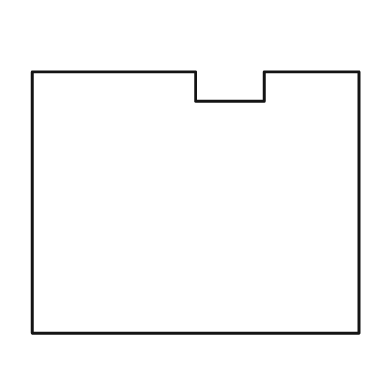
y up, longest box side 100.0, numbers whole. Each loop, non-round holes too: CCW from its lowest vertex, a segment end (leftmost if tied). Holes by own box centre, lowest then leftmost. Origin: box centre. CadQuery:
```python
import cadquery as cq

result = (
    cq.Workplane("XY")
    .moveTo(-50.0, -40.0)
    .lineTo(50.0, -40.0)
    .lineTo(50.0, 40.0)
    .lineTo(21.0, 40.0)
    .lineTo(21.0, 31.0)
    .lineTo(0.0, 31.0)
    .lineTo(0.0, 40.0)
    .lineTo(-50.0, 40.0)
    .close()
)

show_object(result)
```